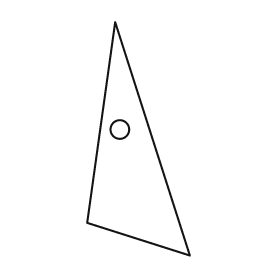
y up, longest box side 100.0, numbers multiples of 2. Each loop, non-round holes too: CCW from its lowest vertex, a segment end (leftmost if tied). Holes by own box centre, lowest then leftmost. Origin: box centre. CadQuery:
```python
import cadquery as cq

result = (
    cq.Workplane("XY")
    .moveTo(22.0, -50.0)
    .lineTo(-10.0, 50.0)
    .lineTo(-22.0, -36.0)
    .close()
    .moveTo(-8.0, 4.0)
    .circle(4.0)
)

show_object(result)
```